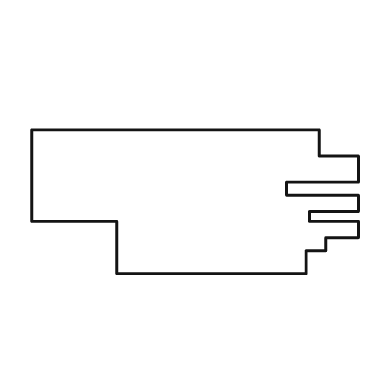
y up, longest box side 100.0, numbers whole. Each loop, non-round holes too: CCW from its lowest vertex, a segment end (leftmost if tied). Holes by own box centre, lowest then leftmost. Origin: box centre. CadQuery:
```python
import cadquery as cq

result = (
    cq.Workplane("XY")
    .moveTo(-24.0, -22.0)
    .lineTo(34.0, -22.0)
    .lineTo(34.0, -15.0)
    .lineTo(40.0, -15.0)
    .lineTo(40.0, -11.0)
    .lineTo(50.0, -11.0)
    .lineTo(50.0, -6.0)
    .lineTo(35.0, -6.0)
    .lineTo(35.0, -3.0)
    .lineTo(50.0, -3.0)
    .lineTo(50.0, 2.0)
    .lineTo(28.0, 2.0)
    .lineTo(28.0, 6.0)
    .lineTo(50.0, 6.0)
    .lineTo(50.0, 14.0)
    .lineTo(38.0, 14.0)
    .lineTo(38.0, 22.0)
    .lineTo(-50.0, 22.0)
    .lineTo(-50.0, -6.0)
    .lineTo(-24.0, -6.0)
    .close()
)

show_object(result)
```